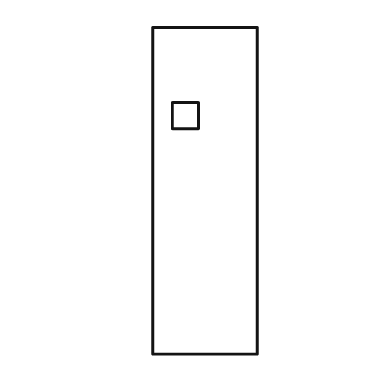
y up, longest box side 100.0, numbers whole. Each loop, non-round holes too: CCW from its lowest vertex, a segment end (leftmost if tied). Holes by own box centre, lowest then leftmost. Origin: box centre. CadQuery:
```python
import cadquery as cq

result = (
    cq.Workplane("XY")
    .moveTo(-16.0, -50.0)
    .lineTo(16.0, -50.0)
    .lineTo(16.0, 50.0)
    .lineTo(-16.0, 50.0)
    .close()
    .moveTo(-10.0, 19.0)
    .lineTo(-2.0, 19.0)
    .lineTo(-2.0, 27.0)
    .lineTo(-10.0, 27.0)
    .close()
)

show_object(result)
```